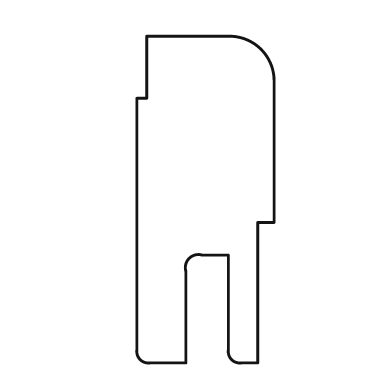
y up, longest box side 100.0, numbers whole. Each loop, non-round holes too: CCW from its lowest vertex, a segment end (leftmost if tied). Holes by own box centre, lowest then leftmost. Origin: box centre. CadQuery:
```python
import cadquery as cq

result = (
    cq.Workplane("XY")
    .moveTo(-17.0, -50.0)
    .lineTo(-6.0, -50.0)
    .lineTo(-6.0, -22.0)
    .threePointArc((-5.0, -18.0), (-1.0, -17.0))
    .lineTo(7.0, -17.0)
    .lineTo(7.0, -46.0)
    .threePointArc((8.0, -49.0), (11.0, -50.0))
    .lineTo(16.0, -50.0)
    .lineTo(16.0, -7.0)
    .lineTo(21.0, -7.0)
    .lineTo(21.0, 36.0)
    .threePointArc((17.0, 46.0), (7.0, 50.0))
    .lineTo(-18.0, 50.0)
    .lineTo(-18.0, 31.0)
    .lineTo(-21.0, 31.0)
    .lineTo(-21.0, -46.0)
    .threePointArc((-20.0, -49.0), (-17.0, -50.0))
    .close()
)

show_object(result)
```